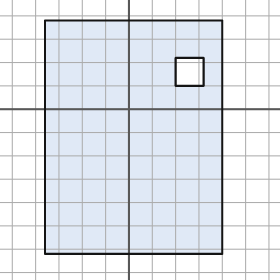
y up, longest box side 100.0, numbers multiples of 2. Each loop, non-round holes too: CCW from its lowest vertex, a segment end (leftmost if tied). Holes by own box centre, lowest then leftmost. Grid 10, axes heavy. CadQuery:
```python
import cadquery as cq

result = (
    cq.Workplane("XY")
    .moveTo(-36.0, -62.0)
    .lineTo(40.0, -62.0)
    .lineTo(40.0, 38.0)
    .lineTo(-36.0, 38.0)
    .close()
    .moveTo(20.0, 10.0)
    .lineTo(32.0, 10.0)
    .lineTo(32.0, 22.0)
    .lineTo(20.0, 22.0)
    .close()
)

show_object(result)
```